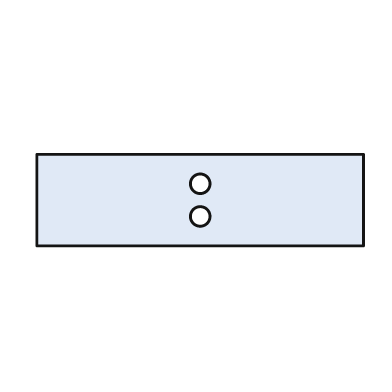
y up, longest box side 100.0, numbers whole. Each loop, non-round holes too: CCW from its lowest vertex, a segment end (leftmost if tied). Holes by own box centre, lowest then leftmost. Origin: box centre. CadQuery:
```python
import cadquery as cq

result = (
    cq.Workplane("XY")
    .moveTo(-50.0, -14.0)
    .lineTo(50.0, -14.0)
    .lineTo(50.0, 14.0)
    .lineTo(-50.0, 14.0)
    .close()
    .moveTo(0.0, -5.0)
    .circle(3.0)
    .moveTo(0.0, 5.0)
    .circle(3.0)
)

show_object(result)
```